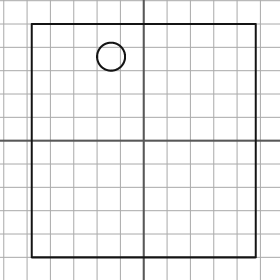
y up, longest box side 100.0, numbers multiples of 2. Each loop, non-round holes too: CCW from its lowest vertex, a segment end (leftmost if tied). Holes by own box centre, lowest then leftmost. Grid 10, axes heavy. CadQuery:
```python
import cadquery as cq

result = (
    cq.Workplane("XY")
    .moveTo(-48.0, -50.0)
    .lineTo(48.0, -50.0)
    .lineTo(48.0, 50.0)
    .lineTo(-48.0, 50.0)
    .close()
    .moveTo(-14.0, 36.0)
    .circle(6.0)
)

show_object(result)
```